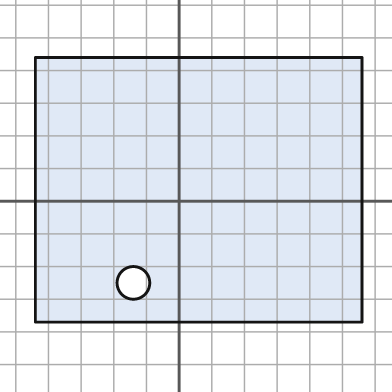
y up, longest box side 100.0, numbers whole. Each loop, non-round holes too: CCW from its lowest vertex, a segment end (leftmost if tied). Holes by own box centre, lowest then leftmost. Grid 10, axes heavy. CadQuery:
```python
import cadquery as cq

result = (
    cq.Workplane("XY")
    .moveTo(-44.0, -37.0)
    .lineTo(56.0, -37.0)
    .lineTo(56.0, 44.0)
    .lineTo(-44.0, 44.0)
    .close()
    .moveTo(-14.0, -25.0)
    .circle(5.0)
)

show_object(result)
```